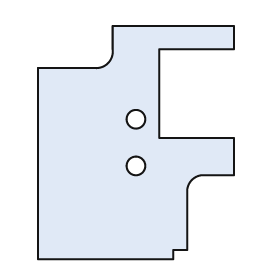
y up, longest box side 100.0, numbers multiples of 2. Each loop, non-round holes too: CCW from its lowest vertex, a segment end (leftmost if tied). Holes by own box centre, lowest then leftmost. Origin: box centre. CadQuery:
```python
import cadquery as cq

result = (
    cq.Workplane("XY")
    .moveTo(-42.0, -50.0)
    .lineTo(16.0, -50.0)
    .lineTo(16.0, -46.0)
    .lineTo(22.0, -46.0)
    .lineTo(22.0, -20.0)
    .threePointArc((24.0, -16.0), (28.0, -14.0))
    .lineTo(42.0, -14.0)
    .lineTo(42.0, 2.0)
    .lineTo(10.0, 2.0)
    .lineTo(10.0, 40.0)
    .lineTo(42.0, 40.0)
    .lineTo(42.0, 50.0)
    .lineTo(-10.0, 50.0)
    .lineTo(-10.0, 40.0)
    .threePointArc((-12.0, 34.0), (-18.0, 32.0))
    .lineTo(-42.0, 32.0)
    .close()
    .moveTo(0.0, -10.0)
    .circle(4.0)
    .moveTo(0.0, 10.0)
    .circle(4.0)
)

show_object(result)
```